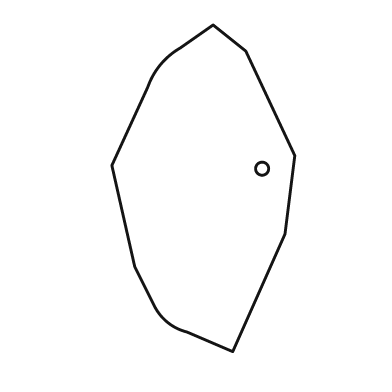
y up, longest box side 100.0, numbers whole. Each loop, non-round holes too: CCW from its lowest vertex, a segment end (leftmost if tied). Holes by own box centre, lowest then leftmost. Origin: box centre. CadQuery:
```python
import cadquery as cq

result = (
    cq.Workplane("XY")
    .moveTo(9.0, -50.0)
    .lineTo(25.0, -14.0)
    .lineTo(28.0, 10.0)
    .lineTo(13.0, 42.0)
    .lineTo(3.0, 50.0)
    .lineTo(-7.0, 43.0)
    .threePointArc((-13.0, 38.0), (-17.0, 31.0))
    .lineTo(-28.0, 7.0)
    .lineTo(-21.0, -24.0)
    .lineTo(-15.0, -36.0)
    .threePointArc((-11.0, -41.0), (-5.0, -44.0))
    .close()
    .moveTo(18.0, 6.0)
    .circle(2.0)
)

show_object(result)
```